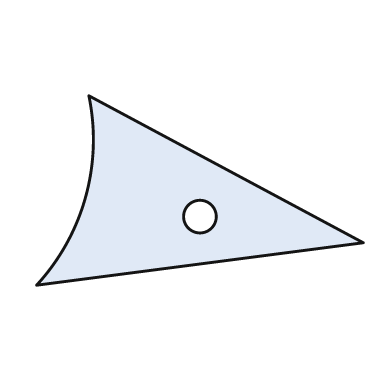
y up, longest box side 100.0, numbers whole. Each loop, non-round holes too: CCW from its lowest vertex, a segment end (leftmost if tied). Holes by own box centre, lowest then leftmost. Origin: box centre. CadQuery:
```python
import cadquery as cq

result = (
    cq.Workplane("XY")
    .moveTo(-50.0, -29.0)
    .lineTo(50.0, -16.0)
    .lineTo(-34.0, 29.0)
    .threePointArc((-35.0, -2.0), (-50.0, -29.0))
    .close()
    .moveTo(0.0, -8.0)
    .circle(5.0)
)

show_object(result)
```